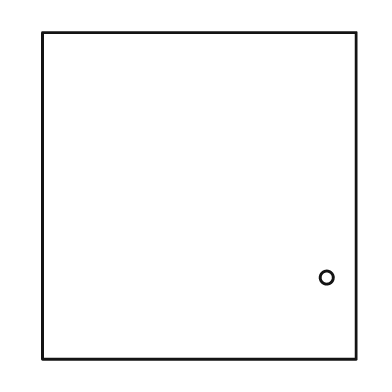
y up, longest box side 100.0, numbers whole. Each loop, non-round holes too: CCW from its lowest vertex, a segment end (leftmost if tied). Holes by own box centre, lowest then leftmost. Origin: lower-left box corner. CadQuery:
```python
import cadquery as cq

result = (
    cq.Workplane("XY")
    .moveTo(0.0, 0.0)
    .lineTo(96.0, 0.0)
    .lineTo(96.0, 100.0)
    .lineTo(0.0, 100.0)
    .close()
    .moveTo(87.0, 25.0)
    .circle(2.0)
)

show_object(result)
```